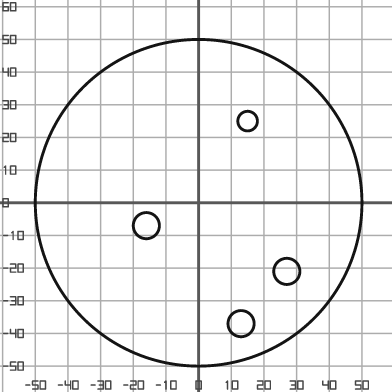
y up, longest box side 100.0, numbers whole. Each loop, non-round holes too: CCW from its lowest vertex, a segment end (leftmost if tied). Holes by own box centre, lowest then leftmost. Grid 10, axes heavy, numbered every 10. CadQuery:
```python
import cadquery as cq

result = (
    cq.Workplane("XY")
    .moveTo(0.0, 0.0)
    .circle(50.0)
    .moveTo(13.0, -37.0)
    .circle(4.0)
    .moveTo(27.0, -21.0)
    .circle(4.0)
    .moveTo(-16.0, -7.0)
    .circle(4.0)
    .moveTo(15.0, 25.0)
    .circle(3.0)
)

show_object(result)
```